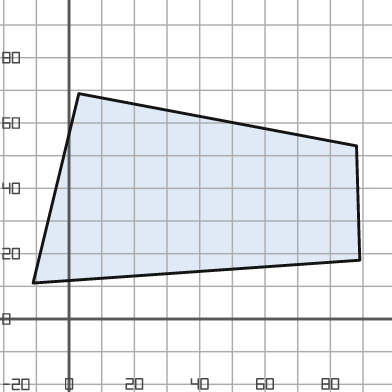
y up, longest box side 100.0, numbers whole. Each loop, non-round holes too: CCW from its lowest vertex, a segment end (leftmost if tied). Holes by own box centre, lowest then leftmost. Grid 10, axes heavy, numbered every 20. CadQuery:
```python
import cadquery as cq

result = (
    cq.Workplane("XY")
    .moveTo(-11.0, 11.0)
    .lineTo(89.0, 18.0)
    .lineTo(88.0, 53.0)
    .lineTo(3.0, 69.0)
    .close()
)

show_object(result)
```